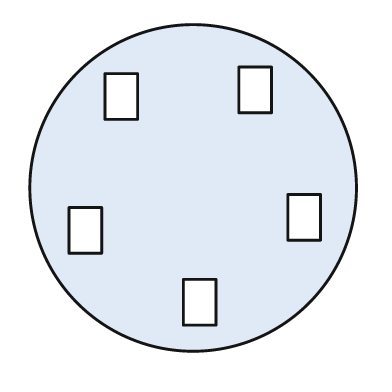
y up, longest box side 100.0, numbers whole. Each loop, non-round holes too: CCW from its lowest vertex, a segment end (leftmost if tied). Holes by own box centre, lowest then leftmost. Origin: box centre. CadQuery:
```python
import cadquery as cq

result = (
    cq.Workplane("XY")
    .moveTo(0.0, 0.0)
    .circle(50.0)
    .moveTo(-3.0, -42.0)
    .lineTo(7.0, -42.0)
    .lineTo(7.0, -28.0)
    .lineTo(-3.0, -28.0)
    .close()
    .moveTo(-38.0, -20.0)
    .lineTo(-28.0, -20.0)
    .lineTo(-28.0, -6.0)
    .lineTo(-38.0, -6.0)
    .close()
    .moveTo(29.0, -16.0)
    .lineTo(39.0, -16.0)
    .lineTo(39.0, -2.0)
    .lineTo(29.0, -2.0)
    .close()
    .moveTo(-27.0, 21.0)
    .lineTo(-17.0, 21.0)
    .lineTo(-17.0, 35.0)
    .lineTo(-27.0, 35.0)
    .close()
    .moveTo(14.0, 23.0)
    .lineTo(24.0, 23.0)
    .lineTo(24.0, 37.0)
    .lineTo(14.0, 37.0)
    .close()
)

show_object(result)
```